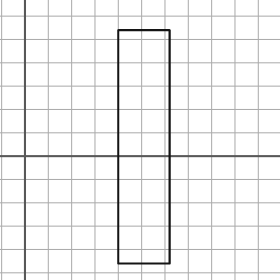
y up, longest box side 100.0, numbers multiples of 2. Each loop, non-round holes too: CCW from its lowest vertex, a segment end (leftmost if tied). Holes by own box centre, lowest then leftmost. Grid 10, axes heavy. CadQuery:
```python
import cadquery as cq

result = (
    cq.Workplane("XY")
    .moveTo(40.0, -46.0)
    .lineTo(62.0, -46.0)
    .lineTo(62.0, 54.0)
    .lineTo(40.0, 54.0)
    .close()
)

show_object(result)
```